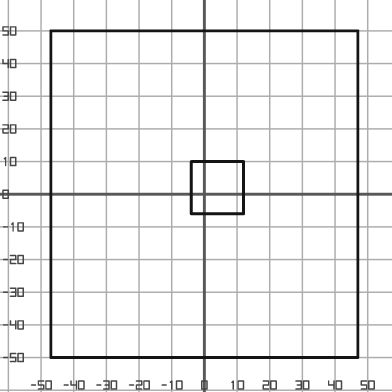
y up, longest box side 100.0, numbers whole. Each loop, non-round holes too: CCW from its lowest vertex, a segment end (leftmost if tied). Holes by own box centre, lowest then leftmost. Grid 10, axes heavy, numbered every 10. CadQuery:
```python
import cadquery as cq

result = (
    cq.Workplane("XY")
    .moveTo(-47.0, -50.0)
    .lineTo(47.0, -50.0)
    .lineTo(47.0, 50.0)
    .lineTo(-47.0, 50.0)
    .close()
    .moveTo(-4.0, -6.0)
    .lineTo(12.0, -6.0)
    .lineTo(12.0, 10.0)
    .lineTo(-4.0, 10.0)
    .close()
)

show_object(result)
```